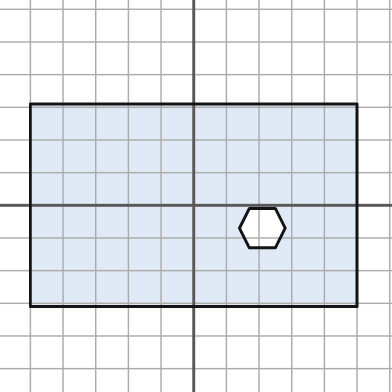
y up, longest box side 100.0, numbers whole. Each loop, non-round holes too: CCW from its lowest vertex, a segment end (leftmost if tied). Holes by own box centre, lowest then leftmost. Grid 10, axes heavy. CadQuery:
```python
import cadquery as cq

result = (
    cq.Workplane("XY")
    .moveTo(-50.0, -31.0)
    .lineTo(50.0, -31.0)
    .lineTo(50.0, 31.0)
    .lineTo(-50.0, 31.0)
    .close()
    .moveTo(17.0, -13.0)
    .lineTo(25.0, -13.0)
    .lineTo(28.0, -7.0)
    .lineTo(25.0, -1.0)
    .lineTo(17.0, -1.0)
    .lineTo(14.0, -7.0)
    .close()
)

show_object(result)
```